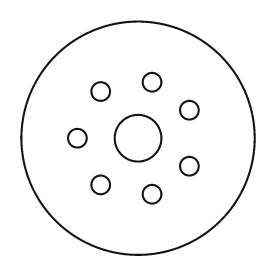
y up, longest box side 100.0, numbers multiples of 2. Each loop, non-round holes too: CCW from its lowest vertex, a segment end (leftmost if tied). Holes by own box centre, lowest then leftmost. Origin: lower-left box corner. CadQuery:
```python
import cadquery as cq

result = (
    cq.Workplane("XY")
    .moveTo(50.0, 50.0)
    .circle(50.0)
    .moveTo(56.0, 26.0)
    .circle(4.0)
    .moveTo(34.0, 30.0)
    .circle(4.0)
    .moveTo(72.0, 38.0)
    .circle(4.0)
    .moveTo(24.0, 50.0)
    .circle(4.0)
    .moveTo(50.0, 50.0)
    .circle(10.0)
    .moveTo(72.0, 62.0)
    .circle(4.0)
    .moveTo(34.0, 70.0)
    .circle(4.0)
    .moveTo(56.0, 74.0)
    .circle(4.0)
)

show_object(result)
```